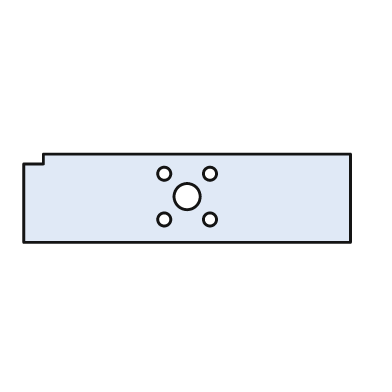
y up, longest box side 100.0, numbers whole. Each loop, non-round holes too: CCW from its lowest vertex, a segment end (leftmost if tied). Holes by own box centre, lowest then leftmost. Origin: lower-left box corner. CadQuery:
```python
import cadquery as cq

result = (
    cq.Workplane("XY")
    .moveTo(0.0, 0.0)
    .lineTo(100.0, 0.0)
    .lineTo(100.0, 27.0)
    .lineTo(6.0, 27.0)
    .lineTo(6.0, 24.0)
    .lineTo(0.0, 24.0)
    .close()
    .moveTo(43.0, 7.0)
    .circle(2.0)
    .moveTo(57.0, 7.0)
    .circle(2.0)
    .moveTo(50.0, 14.0)
    .circle(4.0)
    .moveTo(43.0, 21.0)
    .circle(2.0)
    .moveTo(57.0, 21.0)
    .circle(2.0)
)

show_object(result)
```